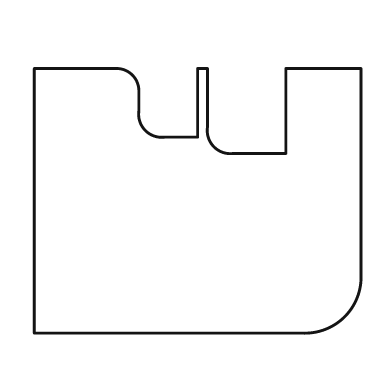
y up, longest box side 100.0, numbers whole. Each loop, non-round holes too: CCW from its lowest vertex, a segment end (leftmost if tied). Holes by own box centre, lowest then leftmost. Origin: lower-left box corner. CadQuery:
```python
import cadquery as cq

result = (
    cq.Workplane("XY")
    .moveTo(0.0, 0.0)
    .lineTo(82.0, 0.0)
    .threePointArc((95.0, 5.0), (100.0, 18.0))
    .lineTo(100.0, 81.0)
    .lineTo(77.0, 81.0)
    .lineTo(77.0, 55.0)
    .lineTo(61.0, 55.0)
    .threePointArc((55.0, 57.0), (53.0, 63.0))
    .lineTo(53.0, 81.0)
    .lineTo(50.0, 81.0)
    .lineTo(50.0, 60.0)
    .lineTo(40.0, 60.0)
    .threePointArc((34.0, 62.0), (32.0, 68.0))
    .lineTo(32.0, 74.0)
    .threePointArc((30.0, 79.0), (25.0, 81.0))
    .lineTo(0.0, 81.0)
    .close()
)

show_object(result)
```